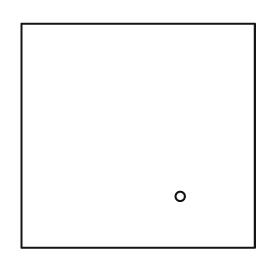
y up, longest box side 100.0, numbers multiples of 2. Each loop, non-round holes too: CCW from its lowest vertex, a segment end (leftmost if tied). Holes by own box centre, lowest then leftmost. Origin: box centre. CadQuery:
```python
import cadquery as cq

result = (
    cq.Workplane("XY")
    .moveTo(-50.0, -48.0)
    .lineTo(50.0, -48.0)
    .lineTo(50.0, 48.0)
    .lineTo(-50.0, 48.0)
    .close()
    .moveTo(18.0, -26.0)
    .circle(2.0)
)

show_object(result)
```